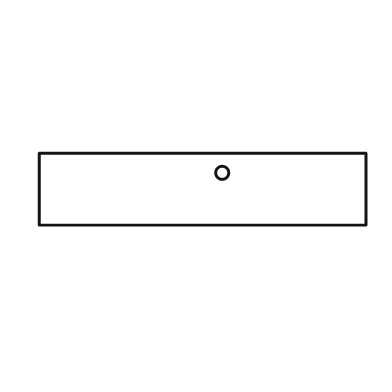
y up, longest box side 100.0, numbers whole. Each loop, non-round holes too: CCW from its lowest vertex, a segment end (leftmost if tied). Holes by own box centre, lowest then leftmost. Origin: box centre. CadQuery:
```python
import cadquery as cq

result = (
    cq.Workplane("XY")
    .moveTo(-50.0, -11.0)
    .lineTo(50.0, -11.0)
    .lineTo(50.0, 11.0)
    .lineTo(-50.0, 11.0)
    .close()
    .moveTo(6.0, 5.0)
    .circle(2.0)
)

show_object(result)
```